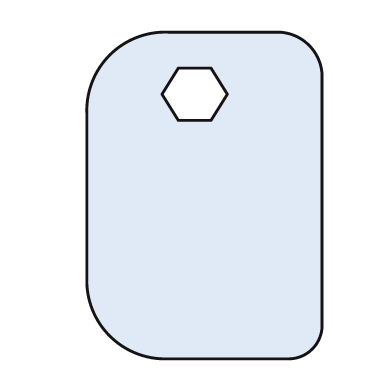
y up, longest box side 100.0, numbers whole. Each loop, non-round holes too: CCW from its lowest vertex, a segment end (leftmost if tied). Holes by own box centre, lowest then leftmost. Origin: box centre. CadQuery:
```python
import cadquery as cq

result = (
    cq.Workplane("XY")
    .moveTo(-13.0, -50.0)
    .lineTo(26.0, -50.0)
    .threePointArc((33.0, -47.0), (36.0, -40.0))
    .lineTo(36.0, 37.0)
    .threePointArc((32.0, 46.0), (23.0, 50.0))
    .lineTo(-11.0, 50.0)
    .threePointArc((-29.0, 43.0), (-36.0, 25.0))
    .lineTo(-36.0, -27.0)
    .threePointArc((-29.0, -43.0), (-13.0, -50.0))
    .close()
    .moveTo(-8.0, 23.0)
    .lineTo(2.0, 23.0)
    .lineTo(7.0, 31.0)
    .lineTo(2.0, 39.0)
    .lineTo(-8.0, 39.0)
    .lineTo(-13.0, 31.0)
    .close()
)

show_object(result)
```